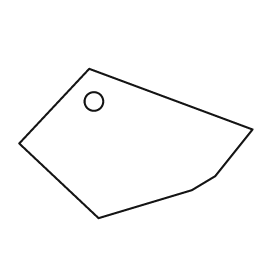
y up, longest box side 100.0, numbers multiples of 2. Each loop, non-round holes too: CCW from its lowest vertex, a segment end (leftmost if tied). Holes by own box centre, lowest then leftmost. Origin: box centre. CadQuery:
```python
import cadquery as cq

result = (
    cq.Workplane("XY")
    .moveTo(-16.0, -32.0)
    .lineTo(24.0, -20.0)
    .lineTo(34.0, -14.0)
    .lineTo(50.0, 6.0)
    .lineTo(-20.0, 32.0)
    .lineTo(-50.0, 0.0)
    .close()
    .moveTo(-18.0, 18.0)
    .circle(4.0)
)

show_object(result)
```